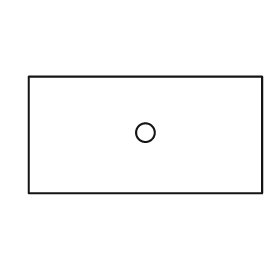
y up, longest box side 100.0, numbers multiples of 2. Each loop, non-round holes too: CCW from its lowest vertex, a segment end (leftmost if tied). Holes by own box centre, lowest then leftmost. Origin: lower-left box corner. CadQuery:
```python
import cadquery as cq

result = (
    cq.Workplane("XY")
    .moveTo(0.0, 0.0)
    .lineTo(100.0, 0.0)
    .lineTo(100.0, 50.0)
    .lineTo(0.0, 50.0)
    .close()
    .moveTo(50.0, 26.0)
    .circle(4.0)
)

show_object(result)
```